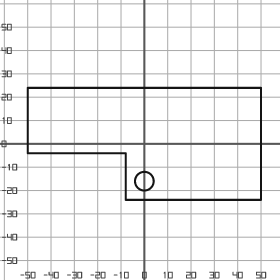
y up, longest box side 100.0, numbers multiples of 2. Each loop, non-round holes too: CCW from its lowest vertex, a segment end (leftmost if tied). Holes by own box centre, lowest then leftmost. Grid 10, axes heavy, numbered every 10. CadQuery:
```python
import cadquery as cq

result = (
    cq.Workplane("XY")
    .moveTo(-8.0, -24.0)
    .lineTo(50.0, -24.0)
    .lineTo(50.0, 24.0)
    .lineTo(-50.0, 24.0)
    .lineTo(-50.0, -4.0)
    .lineTo(-8.0, -4.0)
    .close()
    .moveTo(0.0, -16.0)
    .circle(4.0)
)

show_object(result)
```